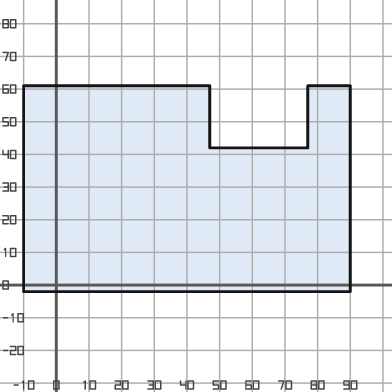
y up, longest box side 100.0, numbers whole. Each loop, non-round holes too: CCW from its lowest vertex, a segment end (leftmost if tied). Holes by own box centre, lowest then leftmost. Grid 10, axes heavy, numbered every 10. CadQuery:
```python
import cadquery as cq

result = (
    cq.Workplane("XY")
    .moveTo(-10.0, -2.0)
    .lineTo(90.0, -2.0)
    .lineTo(90.0, 61.0)
    .lineTo(77.0, 61.0)
    .lineTo(77.0, 42.0)
    .lineTo(47.0, 42.0)
    .lineTo(47.0, 61.0)
    .lineTo(-10.0, 61.0)
    .close()
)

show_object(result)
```